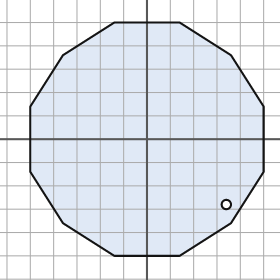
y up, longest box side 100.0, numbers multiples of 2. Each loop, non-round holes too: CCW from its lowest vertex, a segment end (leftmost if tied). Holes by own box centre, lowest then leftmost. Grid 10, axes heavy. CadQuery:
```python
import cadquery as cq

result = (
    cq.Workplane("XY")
    .moveTo(-14.0, -50.0)
    .lineTo(14.0, -50.0)
    .lineTo(36.0, -36.0)
    .lineTo(50.0, -14.0)
    .lineTo(50.0, 14.0)
    .lineTo(36.0, 36.0)
    .lineTo(14.0, 50.0)
    .lineTo(-14.0, 50.0)
    .lineTo(-36.0, 36.0)
    .lineTo(-50.0, 14.0)
    .lineTo(-50.0, -14.0)
    .lineTo(-36.0, -36.0)
    .close()
    .moveTo(34.0, -28.0)
    .circle(2.0)
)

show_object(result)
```